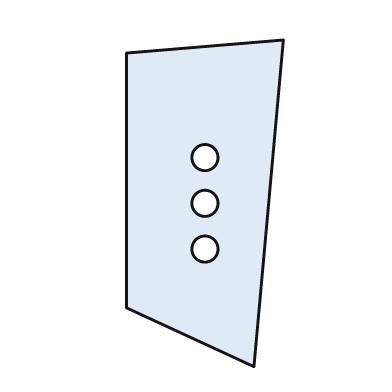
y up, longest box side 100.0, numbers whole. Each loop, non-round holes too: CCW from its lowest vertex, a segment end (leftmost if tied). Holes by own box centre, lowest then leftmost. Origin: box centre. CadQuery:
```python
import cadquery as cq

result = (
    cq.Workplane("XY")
    .moveTo(15.0, -50.0)
    .lineTo(24.0, 50.0)
    .lineTo(-24.0, 46.0)
    .lineTo(-24.0, -32.0)
    .close()
    .moveTo(0.0, -14.0)
    .circle(4.0)
    .moveTo(0.0, 0.0)
    .circle(4.0)
    .moveTo(0.0, 14.0)
    .circle(4.0)
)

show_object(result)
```